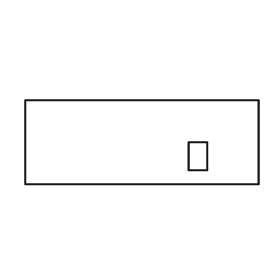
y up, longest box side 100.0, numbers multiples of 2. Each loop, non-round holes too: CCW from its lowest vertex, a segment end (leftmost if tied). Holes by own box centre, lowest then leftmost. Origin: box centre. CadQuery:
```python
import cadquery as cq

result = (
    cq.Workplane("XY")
    .moveTo(-50.0, -18.0)
    .lineTo(50.0, -18.0)
    .lineTo(50.0, 18.0)
    .lineTo(-50.0, 18.0)
    .close()
    .moveTo(20.0, -12.0)
    .lineTo(28.0, -12.0)
    .lineTo(28.0, 0.0)
    .lineTo(20.0, 0.0)
    .close()
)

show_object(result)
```